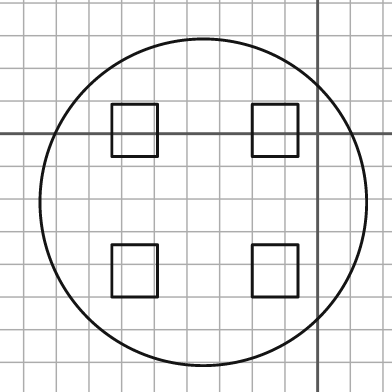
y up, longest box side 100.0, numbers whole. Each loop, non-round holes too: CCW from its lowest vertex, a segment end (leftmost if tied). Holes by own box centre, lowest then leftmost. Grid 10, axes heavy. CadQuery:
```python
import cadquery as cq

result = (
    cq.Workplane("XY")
    .moveTo(-35.0, -21.0)
    .circle(50.0)
    .moveTo(-63.0, -50.0)
    .lineTo(-49.0, -50.0)
    .lineTo(-49.0, -34.0)
    .lineTo(-63.0, -34.0)
    .close()
    .moveTo(-20.0, -50.0)
    .lineTo(-6.0, -50.0)
    .lineTo(-6.0, -34.0)
    .lineTo(-20.0, -34.0)
    .close()
    .moveTo(-63.0, -7.0)
    .lineTo(-49.0, -7.0)
    .lineTo(-49.0, 9.0)
    .lineTo(-63.0, 9.0)
    .close()
    .moveTo(-20.0, -7.0)
    .lineTo(-6.0, -7.0)
    .lineTo(-6.0, 9.0)
    .lineTo(-20.0, 9.0)
    .close()
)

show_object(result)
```